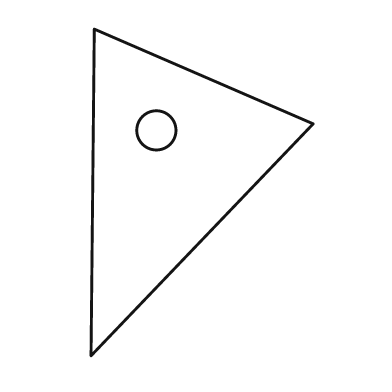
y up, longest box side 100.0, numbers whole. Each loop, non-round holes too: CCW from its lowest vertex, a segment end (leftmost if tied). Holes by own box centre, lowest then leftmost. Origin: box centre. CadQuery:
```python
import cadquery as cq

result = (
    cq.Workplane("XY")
    .moveTo(-34.0, -50.0)
    .lineTo(34.0, 21.0)
    .lineTo(-33.0, 50.0)
    .close()
    .moveTo(-14.0, 19.0)
    .circle(6.0)
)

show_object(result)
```